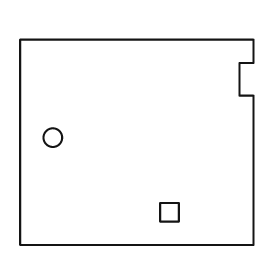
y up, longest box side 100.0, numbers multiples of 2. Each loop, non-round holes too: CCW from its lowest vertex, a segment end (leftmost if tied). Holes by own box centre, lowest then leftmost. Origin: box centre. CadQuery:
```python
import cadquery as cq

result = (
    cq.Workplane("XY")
    .moveTo(-50.0, -44.0)
    .lineTo(50.0, -44.0)
    .lineTo(50.0, 20.0)
    .lineTo(44.0, 20.0)
    .lineTo(44.0, 34.0)
    .lineTo(50.0, 34.0)
    .lineTo(50.0, 44.0)
    .lineTo(-50.0, 44.0)
    .close()
    .moveTo(10.0, -34.0)
    .lineTo(18.0, -34.0)
    .lineTo(18.0, -26.0)
    .lineTo(10.0, -26.0)
    .close()
    .moveTo(-36.0, 2.0)
    .circle(4.0)
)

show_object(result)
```